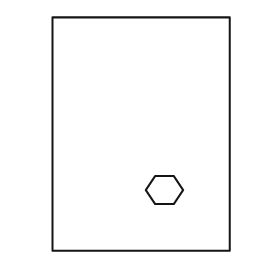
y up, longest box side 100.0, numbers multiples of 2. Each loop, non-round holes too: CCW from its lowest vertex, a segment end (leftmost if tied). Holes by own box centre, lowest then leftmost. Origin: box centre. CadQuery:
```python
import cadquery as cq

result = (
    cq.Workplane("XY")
    .moveTo(-38.0, -50.0)
    .lineTo(38.0, -50.0)
    .lineTo(38.0, 50.0)
    .lineTo(-38.0, 50.0)
    .close()
    .moveTo(6.0, -30.0)
    .lineTo(14.0, -30.0)
    .lineTo(18.0, -24.0)
    .lineTo(14.0, -18.0)
    .lineTo(6.0, -18.0)
    .lineTo(2.0, -24.0)
    .close()
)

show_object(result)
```